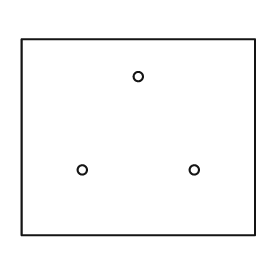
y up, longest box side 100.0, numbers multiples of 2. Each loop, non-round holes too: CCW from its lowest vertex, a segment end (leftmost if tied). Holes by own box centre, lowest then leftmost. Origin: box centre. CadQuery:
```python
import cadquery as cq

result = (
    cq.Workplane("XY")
    .moveTo(-50.0, -42.0)
    .lineTo(50.0, -42.0)
    .lineTo(50.0, 42.0)
    .lineTo(-50.0, 42.0)
    .close()
    .moveTo(-24.0, -14.0)
    .circle(2.0)
    .moveTo(24.0, -14.0)
    .circle(2.0)
    .moveTo(0.0, 26.0)
    .circle(2.0)
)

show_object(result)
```